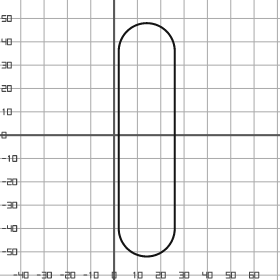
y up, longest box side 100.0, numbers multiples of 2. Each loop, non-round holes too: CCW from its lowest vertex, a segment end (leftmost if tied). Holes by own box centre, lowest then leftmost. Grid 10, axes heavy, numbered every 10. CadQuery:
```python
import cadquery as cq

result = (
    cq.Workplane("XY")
    .moveTo(2.0, -40.0)
    .threePointArc((14.0, -52.0), (26.0, -40.0))
    .lineTo(26.0, 36.0)
    .threePointArc((14.0, 48.0), (2.0, 36.0))
    .close()
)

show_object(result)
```